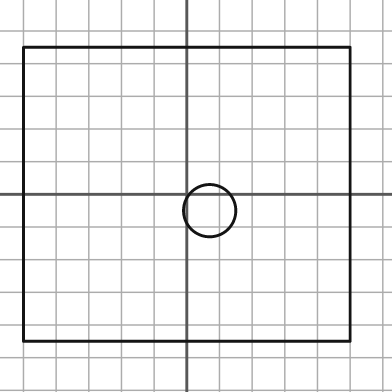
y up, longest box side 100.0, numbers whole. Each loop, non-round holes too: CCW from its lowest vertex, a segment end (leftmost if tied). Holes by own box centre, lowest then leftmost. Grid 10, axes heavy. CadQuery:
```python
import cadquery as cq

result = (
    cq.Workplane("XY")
    .moveTo(-50.0, -45.0)
    .lineTo(50.0, -45.0)
    .lineTo(50.0, 45.0)
    .lineTo(-50.0, 45.0)
    .close()
    .moveTo(7.0, -5.0)
    .circle(8.0)
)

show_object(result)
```